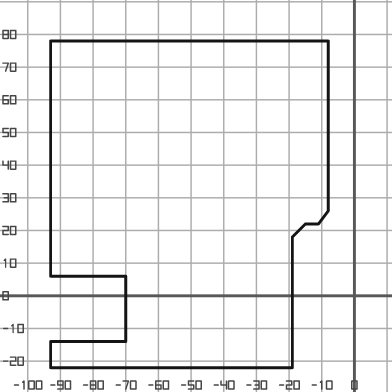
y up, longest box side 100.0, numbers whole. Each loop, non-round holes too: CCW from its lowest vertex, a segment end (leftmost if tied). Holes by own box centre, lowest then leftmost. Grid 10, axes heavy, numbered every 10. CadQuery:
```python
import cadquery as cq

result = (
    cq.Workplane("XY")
    .moveTo(-93.0, -22.0)
    .lineTo(-19.0, -22.0)
    .lineTo(-19.0, 18.0)
    .lineTo(-15.0, 22.0)
    .lineTo(-11.0, 22.0)
    .lineTo(-8.0, 26.0)
    .lineTo(-8.0, 78.0)
    .lineTo(-93.0, 78.0)
    .lineTo(-93.0, 6.0)
    .lineTo(-70.0, 6.0)
    .lineTo(-70.0, -14.0)
    .lineTo(-93.0, -14.0)
    .close()
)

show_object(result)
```